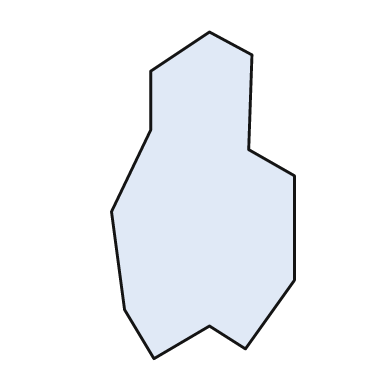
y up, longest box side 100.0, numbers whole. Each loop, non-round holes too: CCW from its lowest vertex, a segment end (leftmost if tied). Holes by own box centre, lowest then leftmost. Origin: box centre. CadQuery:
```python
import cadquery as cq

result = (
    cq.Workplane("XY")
    .moveTo(-15.0, -50.0)
    .lineTo(2.0, -40.0)
    .lineTo(13.0, -47.0)
    .lineTo(28.0, -26.0)
    .lineTo(28.0, 6.0)
    .lineTo(14.0, 14.0)
    .lineTo(15.0, 43.0)
    .lineTo(2.0, 50.0)
    .lineTo(-16.0, 38.0)
    .lineTo(-16.0, 20.0)
    .lineTo(-28.0, -5.0)
    .lineTo(-24.0, -35.0)
    .close()
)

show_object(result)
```